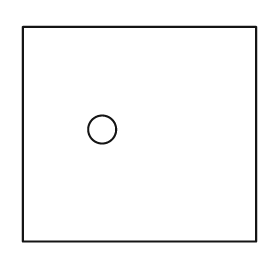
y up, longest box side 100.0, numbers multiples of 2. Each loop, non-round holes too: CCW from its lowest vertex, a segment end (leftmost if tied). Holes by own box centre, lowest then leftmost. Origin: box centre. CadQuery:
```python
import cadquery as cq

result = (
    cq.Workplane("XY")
    .moveTo(-50.0, -46.0)
    .lineTo(50.0, -46.0)
    .lineTo(50.0, 46.0)
    .lineTo(-50.0, 46.0)
    .close()
    .moveTo(-16.0, 2.0)
    .circle(6.0)
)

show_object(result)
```